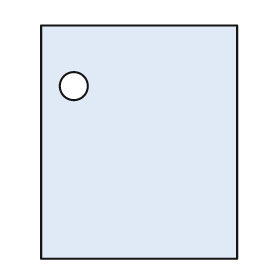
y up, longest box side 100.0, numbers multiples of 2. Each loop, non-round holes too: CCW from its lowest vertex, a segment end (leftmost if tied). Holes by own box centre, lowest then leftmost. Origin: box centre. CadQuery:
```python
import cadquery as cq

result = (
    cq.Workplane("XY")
    .moveTo(-42.0, -50.0)
    .lineTo(42.0, -50.0)
    .lineTo(42.0, 50.0)
    .lineTo(-42.0, 50.0)
    .close()
    .moveTo(-28.0, 24.0)
    .circle(6.0)
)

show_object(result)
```